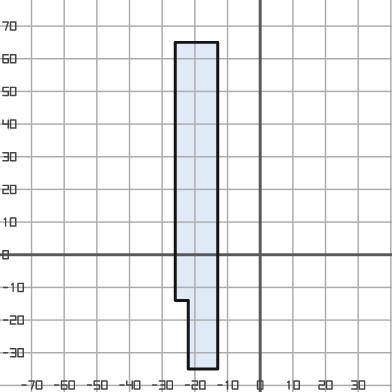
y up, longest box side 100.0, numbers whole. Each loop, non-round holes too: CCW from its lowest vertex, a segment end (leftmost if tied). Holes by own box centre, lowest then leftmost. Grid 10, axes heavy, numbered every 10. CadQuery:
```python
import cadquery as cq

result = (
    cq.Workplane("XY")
    .moveTo(-22.0, -35.0)
    .lineTo(-13.0, -35.0)
    .lineTo(-13.0, 65.0)
    .lineTo(-26.0, 65.0)
    .lineTo(-26.0, -14.0)
    .lineTo(-22.0, -14.0)
    .close()
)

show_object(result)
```